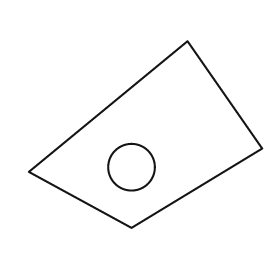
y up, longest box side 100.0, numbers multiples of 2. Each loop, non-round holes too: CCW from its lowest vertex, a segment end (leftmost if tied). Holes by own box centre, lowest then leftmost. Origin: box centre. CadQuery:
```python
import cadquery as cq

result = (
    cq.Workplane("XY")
    .moveTo(-6.0, -40.0)
    .lineTo(50.0, -6.0)
    .lineTo(18.0, 40.0)
    .lineTo(-50.0, -16.0)
    .close()
    .moveTo(-6.0, -14.0)
    .circle(10.0)
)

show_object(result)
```